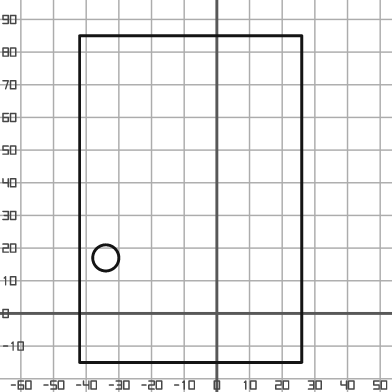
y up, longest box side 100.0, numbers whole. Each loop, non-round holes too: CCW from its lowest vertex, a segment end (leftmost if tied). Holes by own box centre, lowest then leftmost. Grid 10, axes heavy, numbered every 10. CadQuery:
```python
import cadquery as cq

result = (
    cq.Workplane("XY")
    .moveTo(-42.0, -15.0)
    .lineTo(26.0, -15.0)
    .lineTo(26.0, 85.0)
    .lineTo(-42.0, 85.0)
    .close()
    .moveTo(-34.0, 17.0)
    .circle(4.0)
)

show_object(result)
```